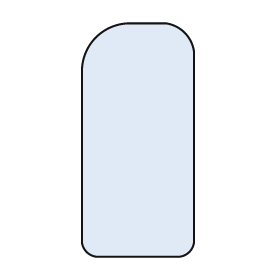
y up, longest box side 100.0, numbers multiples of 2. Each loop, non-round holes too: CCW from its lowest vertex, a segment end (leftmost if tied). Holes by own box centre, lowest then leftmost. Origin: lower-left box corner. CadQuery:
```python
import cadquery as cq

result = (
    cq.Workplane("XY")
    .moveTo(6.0, 0.0)
    .lineTo(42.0, 0.0)
    .threePointArc((46.0, 2.0), (48.0, 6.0))
    .lineTo(48.0, 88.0)
    .threePointArc((44.0, 96.0), (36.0, 100.0))
    .lineTo(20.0, 100.0)
    .threePointArc((6.0, 94.0), (0.0, 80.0))
    .lineTo(0.0, 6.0)
    .threePointArc((2.0, 2.0), (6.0, 0.0))
    .close()
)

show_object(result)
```